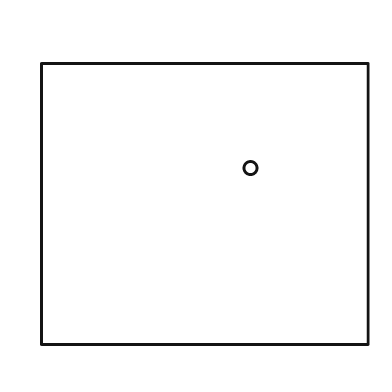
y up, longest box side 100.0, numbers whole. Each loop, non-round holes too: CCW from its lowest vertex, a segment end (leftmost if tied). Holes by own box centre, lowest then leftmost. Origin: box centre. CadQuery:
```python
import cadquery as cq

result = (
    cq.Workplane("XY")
    .moveTo(-50.0, -43.0)
    .lineTo(50.0, -43.0)
    .lineTo(50.0, 43.0)
    .lineTo(-50.0, 43.0)
    .close()
    .moveTo(14.0, 11.0)
    .circle(2.0)
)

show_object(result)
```